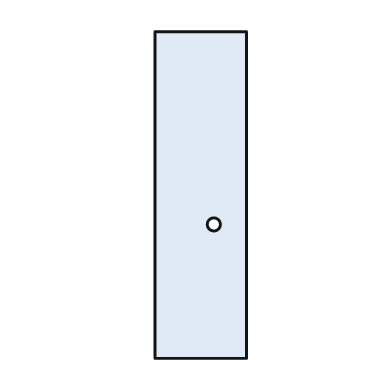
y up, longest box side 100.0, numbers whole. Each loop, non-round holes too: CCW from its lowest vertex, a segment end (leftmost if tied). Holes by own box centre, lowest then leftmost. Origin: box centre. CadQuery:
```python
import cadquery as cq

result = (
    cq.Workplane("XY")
    .moveTo(-14.0, -50.0)
    .lineTo(14.0, -50.0)
    .lineTo(14.0, 50.0)
    .lineTo(-14.0, 50.0)
    .close()
    .moveTo(4.0, -9.0)
    .circle(2.0)
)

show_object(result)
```